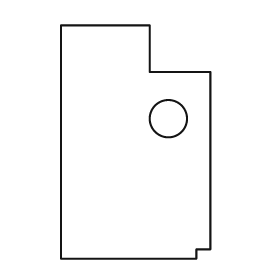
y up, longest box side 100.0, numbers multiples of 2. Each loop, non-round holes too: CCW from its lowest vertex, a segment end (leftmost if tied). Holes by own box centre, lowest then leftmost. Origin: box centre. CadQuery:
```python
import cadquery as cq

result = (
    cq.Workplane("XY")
    .moveTo(-32.0, -50.0)
    .lineTo(26.0, -50.0)
    .lineTo(26.0, -46.0)
    .lineTo(32.0, -46.0)
    .lineTo(32.0, 30.0)
    .lineTo(6.0, 30.0)
    .lineTo(6.0, 50.0)
    .lineTo(-32.0, 50.0)
    .close()
    .moveTo(14.0, 10.0)
    .circle(8.0)
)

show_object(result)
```